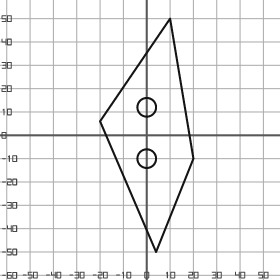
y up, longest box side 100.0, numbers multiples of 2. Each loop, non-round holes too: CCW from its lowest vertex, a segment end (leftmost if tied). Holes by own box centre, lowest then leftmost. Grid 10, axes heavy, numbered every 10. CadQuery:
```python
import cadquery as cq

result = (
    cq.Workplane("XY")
    .moveTo(4.0, -50.0)
    .lineTo(20.0, -10.0)
    .lineTo(10.0, 50.0)
    .lineTo(-20.0, 6.0)
    .close()
    .moveTo(0.0, -10.0)
    .circle(4.0)
    .moveTo(0.0, 12.0)
    .circle(4.0)
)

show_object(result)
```